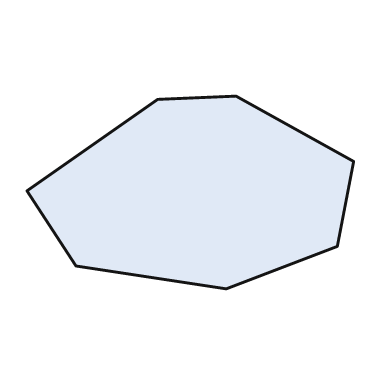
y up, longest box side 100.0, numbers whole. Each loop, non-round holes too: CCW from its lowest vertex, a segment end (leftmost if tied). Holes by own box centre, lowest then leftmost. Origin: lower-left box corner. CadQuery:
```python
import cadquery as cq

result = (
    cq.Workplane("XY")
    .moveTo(61.0, 0.0)
    .lineTo(95.0, 13.0)
    .lineTo(100.0, 39.0)
    .lineTo(64.0, 59.0)
    .lineTo(40.0, 58.0)
    .lineTo(0.0, 30.0)
    .lineTo(15.0, 7.0)
    .close()
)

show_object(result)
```